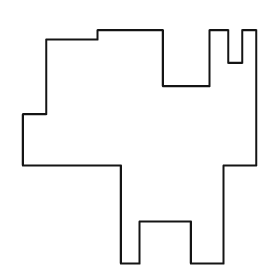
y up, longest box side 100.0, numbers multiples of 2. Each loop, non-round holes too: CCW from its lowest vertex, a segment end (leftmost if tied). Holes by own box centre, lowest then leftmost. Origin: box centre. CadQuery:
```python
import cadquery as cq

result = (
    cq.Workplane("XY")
    .moveTo(-8.0, -50.0)
    .lineTo(0.0, -50.0)
    .lineTo(0.0, -32.0)
    .lineTo(22.0, -32.0)
    .lineTo(22.0, -50.0)
    .lineTo(36.0, -50.0)
    .lineTo(36.0, -8.0)
    .lineTo(50.0, -8.0)
    .lineTo(50.0, 50.0)
    .lineTo(44.0, 50.0)
    .lineTo(44.0, 36.0)
    .lineTo(38.0, 36.0)
    .lineTo(38.0, 50.0)
    .lineTo(30.0, 50.0)
    .lineTo(30.0, 26.0)
    .lineTo(10.0, 26.0)
    .lineTo(10.0, 50.0)
    .lineTo(-18.0, 50.0)
    .lineTo(-18.0, 46.0)
    .lineTo(-40.0, 46.0)
    .lineTo(-40.0, 14.0)
    .lineTo(-50.0, 14.0)
    .lineTo(-50.0, -8.0)
    .lineTo(-8.0, -8.0)
    .close()
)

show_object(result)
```